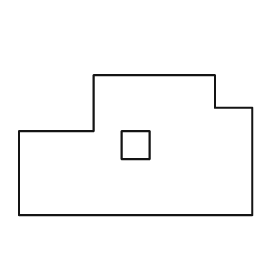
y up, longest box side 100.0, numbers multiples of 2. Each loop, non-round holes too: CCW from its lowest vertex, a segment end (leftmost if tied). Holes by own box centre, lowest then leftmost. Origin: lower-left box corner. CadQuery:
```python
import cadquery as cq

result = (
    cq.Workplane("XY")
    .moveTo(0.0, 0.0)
    .lineTo(100.0, 0.0)
    .lineTo(100.0, 46.0)
    .lineTo(84.0, 46.0)
    .lineTo(84.0, 60.0)
    .lineTo(32.0, 60.0)
    .lineTo(32.0, 36.0)
    .lineTo(0.0, 36.0)
    .close()
    .moveTo(44.0, 24.0)
    .lineTo(56.0, 24.0)
    .lineTo(56.0, 36.0)
    .lineTo(44.0, 36.0)
    .close()
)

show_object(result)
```